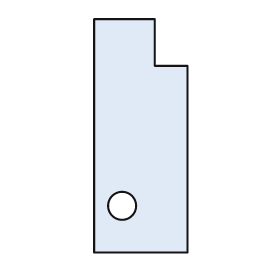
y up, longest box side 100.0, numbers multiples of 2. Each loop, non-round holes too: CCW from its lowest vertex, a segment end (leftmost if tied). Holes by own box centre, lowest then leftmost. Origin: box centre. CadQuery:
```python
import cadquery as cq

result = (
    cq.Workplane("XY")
    .moveTo(-20.0, -50.0)
    .lineTo(20.0, -50.0)
    .lineTo(20.0, 30.0)
    .lineTo(6.0, 30.0)
    .lineTo(6.0, 50.0)
    .lineTo(-20.0, 50.0)
    .close()
    .moveTo(-8.0, -30.0)
    .circle(6.0)
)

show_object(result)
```